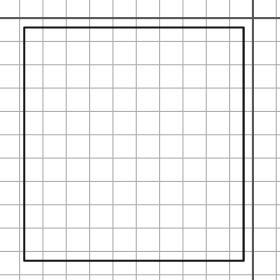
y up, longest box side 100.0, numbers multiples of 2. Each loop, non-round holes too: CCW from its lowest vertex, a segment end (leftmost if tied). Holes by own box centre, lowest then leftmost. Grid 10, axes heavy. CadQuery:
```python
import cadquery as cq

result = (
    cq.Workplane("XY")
    .moveTo(-98.0, -104.0)
    .lineTo(-4.0, -104.0)
    .lineTo(-4.0, -4.0)
    .lineTo(-98.0, -4.0)
    .close()
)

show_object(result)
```